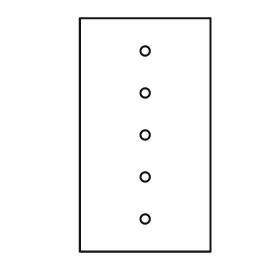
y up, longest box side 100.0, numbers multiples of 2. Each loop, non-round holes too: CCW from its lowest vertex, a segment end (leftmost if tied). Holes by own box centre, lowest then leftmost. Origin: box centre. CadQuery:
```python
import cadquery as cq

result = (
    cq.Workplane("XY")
    .moveTo(-28.0, -50.0)
    .lineTo(28.0, -50.0)
    .lineTo(28.0, 50.0)
    .lineTo(-28.0, 50.0)
    .close()
    .moveTo(0.0, -36.0)
    .circle(2.0)
    .moveTo(0.0, -18.0)
    .circle(2.0)
    .moveTo(0.0, 0.0)
    .circle(2.0)
    .moveTo(0.0, 18.0)
    .circle(2.0)
    .moveTo(0.0, 36.0)
    .circle(2.0)
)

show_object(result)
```